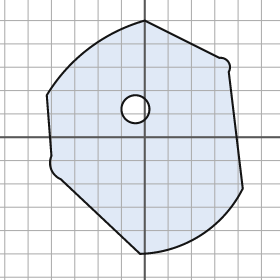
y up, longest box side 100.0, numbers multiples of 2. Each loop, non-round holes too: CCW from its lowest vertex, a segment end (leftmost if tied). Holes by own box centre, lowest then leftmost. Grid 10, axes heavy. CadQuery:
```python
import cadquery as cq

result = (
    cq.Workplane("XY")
    .moveTo(-2.0, -50.0)
    .threePointArc((24.0, -42.0), (42.0, -22.0))
    .lineTo(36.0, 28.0)
    .threePointArc((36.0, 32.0), (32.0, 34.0))
    .lineTo(0.0, 50.0)
    .threePointArc((-24.0, 38.0), (-42.0, 18.0))
    .lineTo(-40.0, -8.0)
    .threePointArc((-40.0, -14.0), (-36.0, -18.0))
    .close()
    .moveTo(-4.0, 12.0)
    .circle(6.0)
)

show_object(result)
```